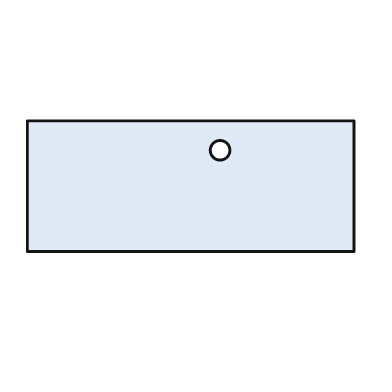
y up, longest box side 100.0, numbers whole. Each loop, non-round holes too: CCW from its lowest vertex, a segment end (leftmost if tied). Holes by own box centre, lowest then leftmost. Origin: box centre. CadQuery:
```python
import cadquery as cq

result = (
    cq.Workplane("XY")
    .moveTo(-50.0, -20.0)
    .lineTo(50.0, -20.0)
    .lineTo(50.0, 20.0)
    .lineTo(-50.0, 20.0)
    .close()
    .moveTo(9.0, 11.0)
    .circle(3.0)
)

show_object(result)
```